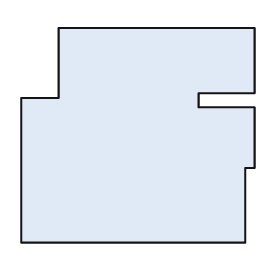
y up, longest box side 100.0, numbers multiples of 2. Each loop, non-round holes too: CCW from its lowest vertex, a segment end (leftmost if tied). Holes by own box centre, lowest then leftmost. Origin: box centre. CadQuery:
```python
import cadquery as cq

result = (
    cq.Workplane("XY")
    .moveTo(-50.0, -46.0)
    .lineTo(46.0, -46.0)
    .lineTo(46.0, -14.0)
    .lineTo(50.0, -14.0)
    .lineTo(50.0, 12.0)
    .lineTo(26.0, 12.0)
    .lineTo(26.0, 18.0)
    .lineTo(50.0, 18.0)
    .lineTo(50.0, 46.0)
    .lineTo(-34.0, 46.0)
    .lineTo(-34.0, 16.0)
    .lineTo(-50.0, 16.0)
    .close()
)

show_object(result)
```